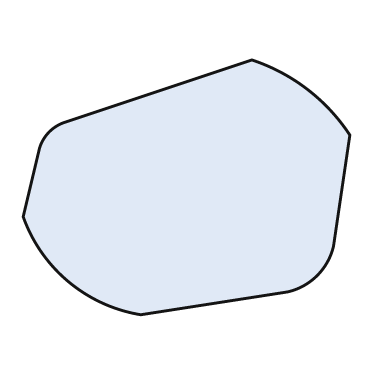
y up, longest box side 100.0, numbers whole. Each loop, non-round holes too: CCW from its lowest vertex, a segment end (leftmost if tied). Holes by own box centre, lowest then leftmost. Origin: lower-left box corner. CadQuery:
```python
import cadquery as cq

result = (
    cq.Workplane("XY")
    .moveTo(36.0, 0.0)
    .lineTo(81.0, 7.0)
    .threePointArc((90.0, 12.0), (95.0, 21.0))
    .lineTo(100.0, 55.0)
    .threePointArc((87.0, 69.0), (70.0, 78.0))
    .lineTo(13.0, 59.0)
    .threePointArc((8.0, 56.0), (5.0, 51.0))
    .lineTo(0.0, 30.0)
    .threePointArc((14.0, 10.0), (36.0, 0.0))
    .close()
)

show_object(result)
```